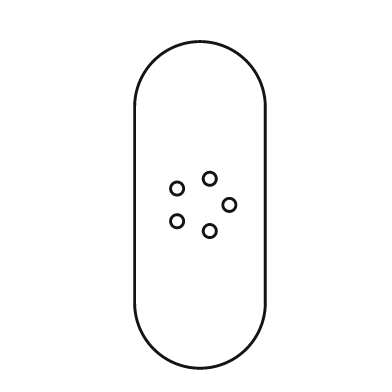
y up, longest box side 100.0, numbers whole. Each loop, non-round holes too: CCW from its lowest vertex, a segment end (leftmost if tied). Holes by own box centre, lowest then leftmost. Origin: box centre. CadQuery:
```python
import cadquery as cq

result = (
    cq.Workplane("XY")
    .moveTo(-20.0, -30.0)
    .threePointArc((0.0, -50.0), (20.0, -30.0))
    .lineTo(20.0, 30.0)
    .threePointArc((0.0, 50.0), (-20.0, 30.0))
    .close()
    .moveTo(3.0, -8.0)
    .circle(2.0)
    .moveTo(-7.0, -5.0)
    .circle(2.0)
    .moveTo(9.0, 0.0)
    .circle(2.0)
    .moveTo(-7.0, 5.0)
    .circle(2.0)
    .moveTo(3.0, 8.0)
    .circle(2.0)
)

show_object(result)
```